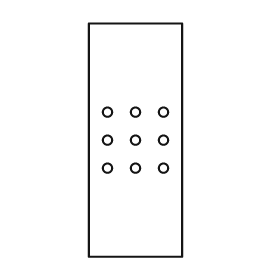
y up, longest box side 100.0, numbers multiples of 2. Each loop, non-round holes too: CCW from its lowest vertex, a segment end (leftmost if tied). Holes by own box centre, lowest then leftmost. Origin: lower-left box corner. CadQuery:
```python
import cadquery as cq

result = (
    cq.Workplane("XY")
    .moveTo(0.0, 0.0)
    .lineTo(40.0, 0.0)
    .lineTo(40.0, 100.0)
    .lineTo(0.0, 100.0)
    .close()
    .moveTo(8.0, 38.0)
    .circle(2.0)
    .moveTo(20.0, 38.0)
    .circle(2.0)
    .moveTo(32.0, 38.0)
    .circle(2.0)
    .moveTo(8.0, 50.0)
    .circle(2.0)
    .moveTo(20.0, 50.0)
    .circle(2.0)
    .moveTo(32.0, 50.0)
    .circle(2.0)
    .moveTo(8.0, 62.0)
    .circle(2.0)
    .moveTo(20.0, 62.0)
    .circle(2.0)
    .moveTo(32.0, 62.0)
    .circle(2.0)
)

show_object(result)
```